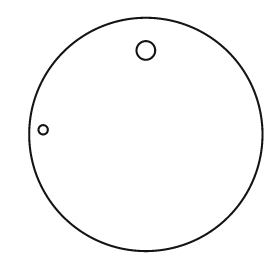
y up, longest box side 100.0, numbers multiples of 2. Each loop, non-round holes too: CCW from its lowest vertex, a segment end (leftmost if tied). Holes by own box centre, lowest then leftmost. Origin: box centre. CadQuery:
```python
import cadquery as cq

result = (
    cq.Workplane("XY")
    .moveTo(0.0, 0.0)
    .circle(50.0)
    .moveTo(-44.0, 2.0)
    .circle(2.0)
    .moveTo(0.0, 36.0)
    .circle(4.0)
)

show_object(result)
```